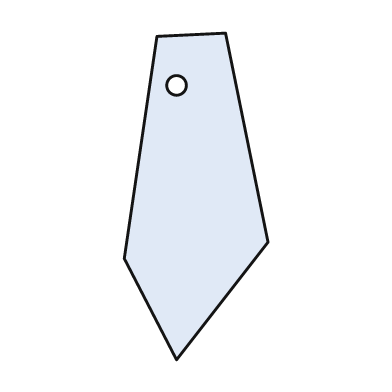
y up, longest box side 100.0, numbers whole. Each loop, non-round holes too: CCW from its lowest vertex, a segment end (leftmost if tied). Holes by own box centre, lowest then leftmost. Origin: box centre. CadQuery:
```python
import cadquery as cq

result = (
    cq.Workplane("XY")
    .moveTo(-6.0, -50.0)
    .lineTo(22.0, -14.0)
    .lineTo(9.0, 50.0)
    .lineTo(-12.0, 49.0)
    .lineTo(-22.0, -19.0)
    .close()
    .moveTo(-6.0, 34.0)
    .circle(3.0)
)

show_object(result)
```